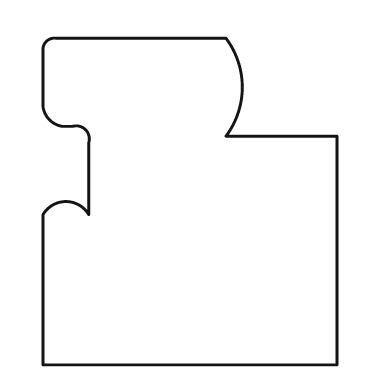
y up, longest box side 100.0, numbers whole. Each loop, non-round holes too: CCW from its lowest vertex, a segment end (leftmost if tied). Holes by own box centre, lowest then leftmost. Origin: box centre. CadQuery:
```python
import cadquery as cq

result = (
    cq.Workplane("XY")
    .moveTo(-45.0, -50.0)
    .lineTo(45.0, -50.0)
    .lineTo(45.0, 20.0)
    .lineTo(11.0, 20.0)
    .threePointArc((16.0, 35.0), (11.0, 50.0))
    .lineTo(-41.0, 50.0)
    .threePointArc((-44.0, 49.0), (-45.0, 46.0))
    .lineTo(-45.0, 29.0)
    .threePointArc((-43.0, 25.0), (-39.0, 23.0))
    .lineTo(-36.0, 23.0)
    .threePointArc((-32.0, 22.0), (-31.0, 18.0))
    .lineTo(-31.0, -4.0)
    .threePointArc((-38.0, 0.0), (-45.0, -4.0))
    .close()
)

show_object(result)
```